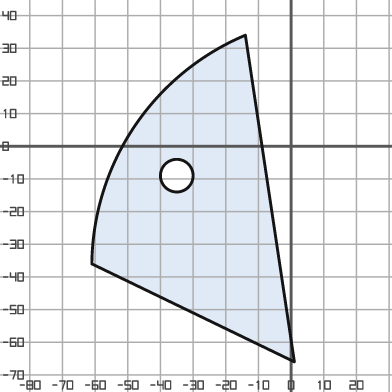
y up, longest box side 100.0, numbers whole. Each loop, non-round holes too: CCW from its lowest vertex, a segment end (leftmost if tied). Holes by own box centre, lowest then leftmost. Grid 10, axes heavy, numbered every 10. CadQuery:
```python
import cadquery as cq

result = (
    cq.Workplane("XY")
    .moveTo(1.0, -66.0)
    .lineTo(-14.0, 34.0)
    .threePointArc((-48.0, 6.0), (-61.0, -36.0))
    .close()
    .moveTo(-35.0, -9.0)
    .circle(5.0)
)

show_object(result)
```